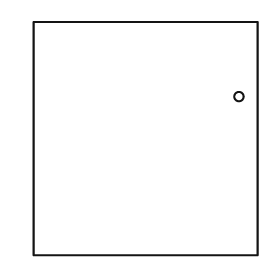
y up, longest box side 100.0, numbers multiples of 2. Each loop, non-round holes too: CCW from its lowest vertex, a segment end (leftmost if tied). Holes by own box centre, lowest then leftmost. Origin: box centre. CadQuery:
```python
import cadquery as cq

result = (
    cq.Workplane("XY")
    .moveTo(-48.0, -50.0)
    .lineTo(48.0, -50.0)
    .lineTo(48.0, 50.0)
    .lineTo(-48.0, 50.0)
    .close()
    .moveTo(40.0, 18.0)
    .circle(2.0)
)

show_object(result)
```